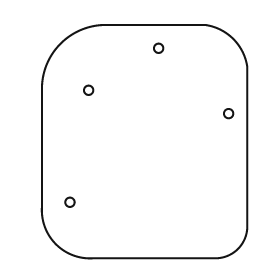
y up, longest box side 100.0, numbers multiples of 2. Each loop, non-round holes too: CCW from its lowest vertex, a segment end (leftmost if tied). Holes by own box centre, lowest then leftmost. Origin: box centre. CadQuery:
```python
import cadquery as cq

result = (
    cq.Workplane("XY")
    .moveTo(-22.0, -50.0)
    .lineTo(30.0, -50.0)
    .threePointArc((40.0, -46.0), (44.0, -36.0))
    .lineTo(44.0, 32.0)
    .threePointArc((38.0, 44.0), (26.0, 50.0))
    .lineTo(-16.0, 50.0)
    .threePointArc((-36.0, 42.0), (-44.0, 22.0))
    .lineTo(-44.0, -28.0)
    .threePointArc((-38.0, -44.0), (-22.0, -50.0))
    .close()
    .moveTo(-32.0, -26.0)
    .circle(2.0)
    .moveTo(36.0, 12.0)
    .circle(2.0)
    .moveTo(-24.0, 22.0)
    .circle(2.0)
    .moveTo(6.0, 40.0)
    .circle(2.0)
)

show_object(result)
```